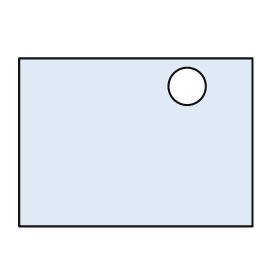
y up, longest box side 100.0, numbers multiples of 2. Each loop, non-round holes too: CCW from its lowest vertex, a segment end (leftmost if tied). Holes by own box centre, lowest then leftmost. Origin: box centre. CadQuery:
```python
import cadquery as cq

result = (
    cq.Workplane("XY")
    .moveTo(-50.0, -36.0)
    .lineTo(50.0, -36.0)
    .lineTo(50.0, 36.0)
    .lineTo(-50.0, 36.0)
    .close()
    .moveTo(22.0, 24.0)
    .circle(8.0)
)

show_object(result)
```